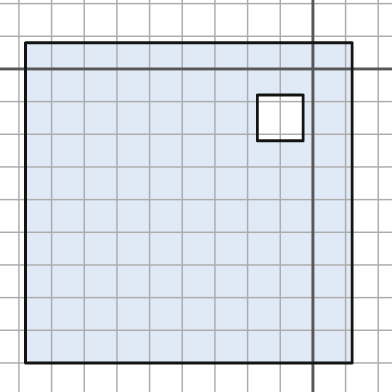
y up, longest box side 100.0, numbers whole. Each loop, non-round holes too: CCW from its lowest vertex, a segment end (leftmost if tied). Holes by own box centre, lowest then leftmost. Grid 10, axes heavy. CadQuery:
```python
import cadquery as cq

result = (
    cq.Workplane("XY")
    .moveTo(-88.0, -90.0)
    .lineTo(12.0, -90.0)
    .lineTo(12.0, 8.0)
    .lineTo(-88.0, 8.0)
    .close()
    .moveTo(-17.0, -22.0)
    .lineTo(-3.0, -22.0)
    .lineTo(-3.0, -8.0)
    .lineTo(-17.0, -8.0)
    .close()
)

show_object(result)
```